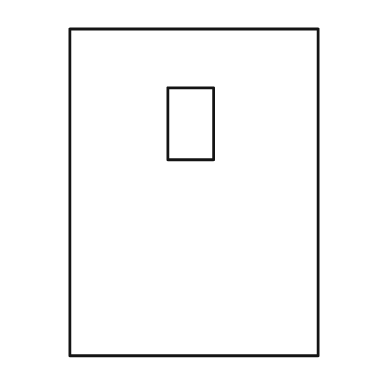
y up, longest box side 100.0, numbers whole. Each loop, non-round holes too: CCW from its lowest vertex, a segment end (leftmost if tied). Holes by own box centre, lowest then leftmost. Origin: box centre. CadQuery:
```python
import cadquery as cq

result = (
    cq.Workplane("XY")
    .moveTo(-38.0, -50.0)
    .lineTo(38.0, -50.0)
    .lineTo(38.0, 50.0)
    .lineTo(-38.0, 50.0)
    .close()
    .moveTo(-8.0, 10.0)
    .lineTo(6.0, 10.0)
    .lineTo(6.0, 32.0)
    .lineTo(-8.0, 32.0)
    .close()
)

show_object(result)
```